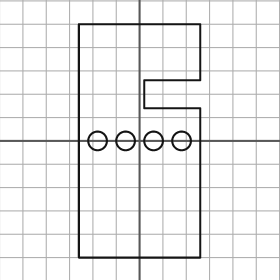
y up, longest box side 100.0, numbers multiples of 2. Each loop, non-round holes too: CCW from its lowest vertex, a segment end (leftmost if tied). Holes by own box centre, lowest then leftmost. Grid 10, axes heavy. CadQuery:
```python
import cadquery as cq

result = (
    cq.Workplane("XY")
    .moveTo(-26.0, -50.0)
    .lineTo(26.0, -50.0)
    .lineTo(26.0, 14.0)
    .lineTo(2.0, 14.0)
    .lineTo(2.0, 26.0)
    .lineTo(26.0, 26.0)
    .lineTo(26.0, 50.0)
    .lineTo(-26.0, 50.0)
    .close()
    .moveTo(-18.0, 0.0)
    .circle(4.0)
    .moveTo(-6.0, 0.0)
    .circle(4.0)
    .moveTo(6.0, 0.0)
    .circle(4.0)
    .moveTo(18.0, 0.0)
    .circle(4.0)
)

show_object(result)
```